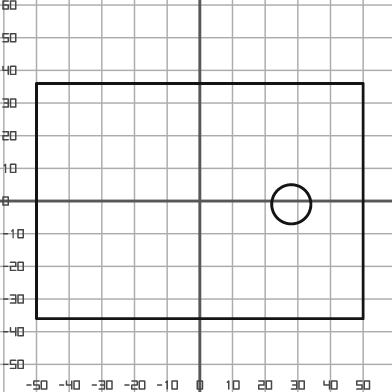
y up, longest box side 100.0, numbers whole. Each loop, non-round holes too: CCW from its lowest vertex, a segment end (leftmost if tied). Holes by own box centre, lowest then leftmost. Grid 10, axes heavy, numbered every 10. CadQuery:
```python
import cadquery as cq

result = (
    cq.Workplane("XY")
    .moveTo(-50.0, -36.0)
    .lineTo(50.0, -36.0)
    .lineTo(50.0, 36.0)
    .lineTo(-50.0, 36.0)
    .close()
    .moveTo(28.0, -1.0)
    .circle(6.0)
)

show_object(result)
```